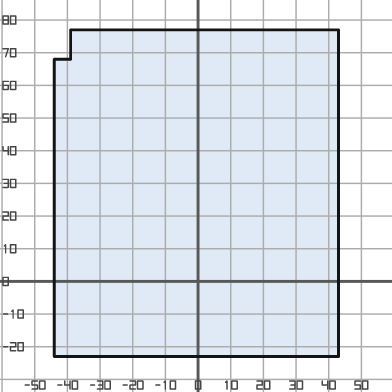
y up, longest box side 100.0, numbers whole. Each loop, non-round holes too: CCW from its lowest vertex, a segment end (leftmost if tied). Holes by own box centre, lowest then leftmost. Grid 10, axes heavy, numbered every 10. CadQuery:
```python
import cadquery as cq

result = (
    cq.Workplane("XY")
    .moveTo(-44.0, -23.0)
    .lineTo(43.0, -23.0)
    .lineTo(43.0, 77.0)
    .lineTo(-39.0, 77.0)
    .lineTo(-39.0, 68.0)
    .lineTo(-44.0, 68.0)
    .close()
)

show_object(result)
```